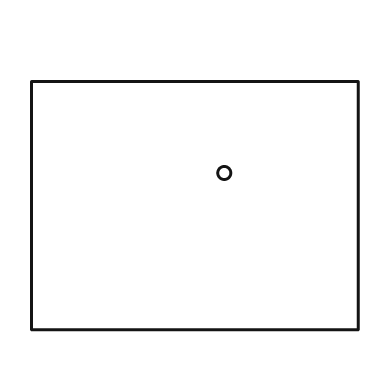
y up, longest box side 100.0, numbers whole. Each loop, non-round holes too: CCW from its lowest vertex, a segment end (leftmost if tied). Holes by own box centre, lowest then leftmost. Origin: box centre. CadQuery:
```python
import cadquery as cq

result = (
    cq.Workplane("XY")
    .moveTo(-50.0, -38.0)
    .lineTo(50.0, -38.0)
    .lineTo(50.0, 38.0)
    .lineTo(-50.0, 38.0)
    .close()
    .moveTo(9.0, 10.0)
    .circle(2.0)
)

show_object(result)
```